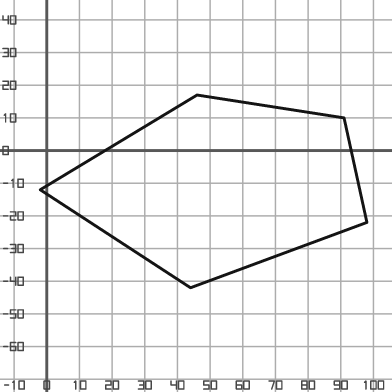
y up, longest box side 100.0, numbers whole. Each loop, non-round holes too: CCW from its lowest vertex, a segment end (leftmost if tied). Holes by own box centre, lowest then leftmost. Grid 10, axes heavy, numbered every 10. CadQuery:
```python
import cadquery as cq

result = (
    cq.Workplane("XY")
    .moveTo(44.0, -42.0)
    .lineTo(98.0, -22.0)
    .lineTo(91.0, 10.0)
    .lineTo(46.0, 17.0)
    .lineTo(-2.0, -12.0)
    .close()
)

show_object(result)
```